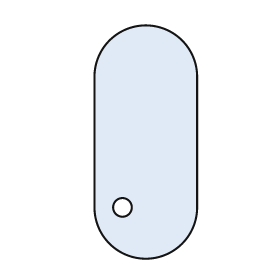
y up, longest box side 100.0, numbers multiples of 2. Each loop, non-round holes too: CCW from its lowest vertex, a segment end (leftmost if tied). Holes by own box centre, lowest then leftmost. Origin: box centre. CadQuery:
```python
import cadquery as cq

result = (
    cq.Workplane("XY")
    .moveTo(-22.0, -28.0)
    .threePointArc((0.0, -50.0), (22.0, -28.0))
    .lineTo(22.0, 28.0)
    .threePointArc((0.0, 50.0), (-22.0, 28.0))
    .close()
    .moveTo(-10.0, -28.0)
    .circle(4.0)
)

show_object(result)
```